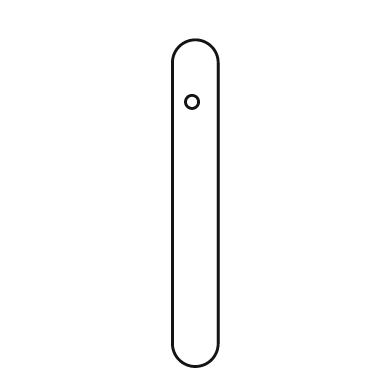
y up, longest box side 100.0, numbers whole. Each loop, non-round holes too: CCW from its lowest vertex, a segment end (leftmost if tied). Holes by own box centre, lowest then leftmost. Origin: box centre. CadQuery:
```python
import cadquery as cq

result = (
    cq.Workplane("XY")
    .moveTo(-7.0, -43.0)
    .threePointArc((0.0, -50.0), (7.0, -43.0))
    .lineTo(7.0, 43.0)
    .threePointArc((0.0, 50.0), (-7.0, 43.0))
    .close()
    .moveTo(-1.0, 31.0)
    .circle(2.0)
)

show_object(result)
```